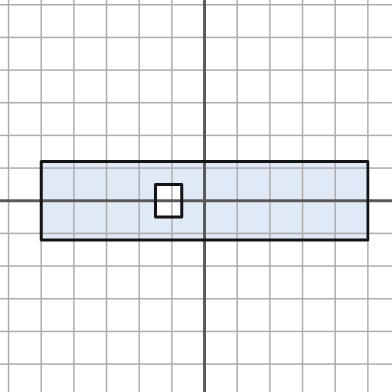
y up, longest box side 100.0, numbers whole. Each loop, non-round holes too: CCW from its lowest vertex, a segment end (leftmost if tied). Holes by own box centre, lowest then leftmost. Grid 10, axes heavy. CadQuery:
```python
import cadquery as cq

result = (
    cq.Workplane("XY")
    .moveTo(-50.0, -12.0)
    .lineTo(50.0, -12.0)
    .lineTo(50.0, 12.0)
    .lineTo(-50.0, 12.0)
    .close()
    .moveTo(-15.0, -5.0)
    .lineTo(-7.0, -5.0)
    .lineTo(-7.0, 5.0)
    .lineTo(-15.0, 5.0)
    .close()
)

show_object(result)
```